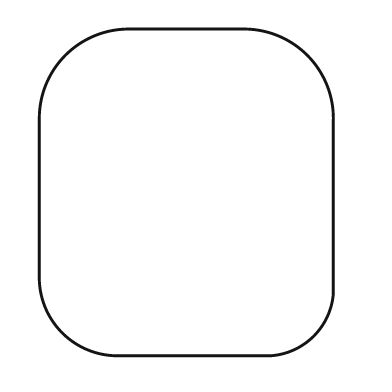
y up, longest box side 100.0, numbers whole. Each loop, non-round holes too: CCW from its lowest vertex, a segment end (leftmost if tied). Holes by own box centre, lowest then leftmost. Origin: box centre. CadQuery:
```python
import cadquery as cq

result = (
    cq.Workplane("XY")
    .moveTo(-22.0, -50.0)
    .lineTo(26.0, -50.0)
    .threePointArc((39.0, -44.0), (45.0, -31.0))
    .lineTo(45.0, 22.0)
    .threePointArc((37.0, 42.0), (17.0, 50.0))
    .lineTo(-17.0, 50.0)
    .threePointArc((-37.0, 42.0), (-45.0, 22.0))
    .lineTo(-45.0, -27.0)
    .threePointArc((-38.0, -43.0), (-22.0, -50.0))
    .close()
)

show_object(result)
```